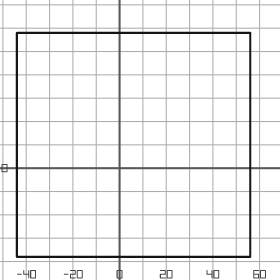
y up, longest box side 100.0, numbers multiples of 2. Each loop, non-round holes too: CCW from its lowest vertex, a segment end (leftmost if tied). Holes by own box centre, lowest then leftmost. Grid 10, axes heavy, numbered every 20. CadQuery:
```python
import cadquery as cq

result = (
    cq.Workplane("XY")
    .moveTo(-44.0, -38.0)
    .lineTo(56.0, -38.0)
    .lineTo(56.0, 58.0)
    .lineTo(-44.0, 58.0)
    .close()
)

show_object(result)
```